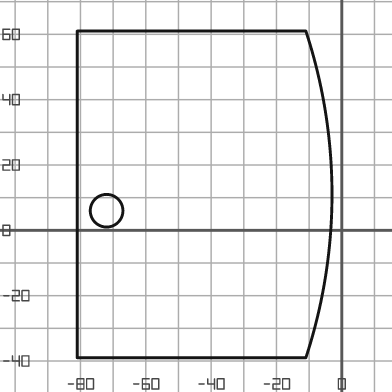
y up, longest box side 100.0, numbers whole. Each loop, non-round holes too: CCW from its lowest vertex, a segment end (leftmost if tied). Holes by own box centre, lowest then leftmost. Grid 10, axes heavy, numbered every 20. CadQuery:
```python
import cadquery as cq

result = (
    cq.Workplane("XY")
    .moveTo(-81.0, -39.0)
    .lineTo(-11.0, -39.0)
    .threePointArc((-3.0, 11.0), (-11.0, 61.0))
    .lineTo(-81.0, 61.0)
    .close()
    .moveTo(-72.0, 6.0)
    .circle(5.0)
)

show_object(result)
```